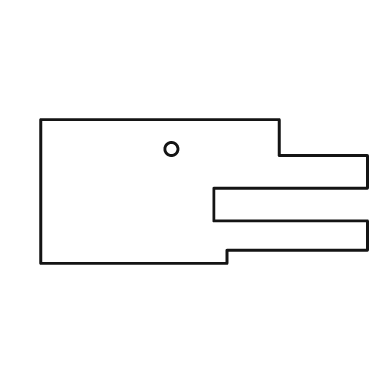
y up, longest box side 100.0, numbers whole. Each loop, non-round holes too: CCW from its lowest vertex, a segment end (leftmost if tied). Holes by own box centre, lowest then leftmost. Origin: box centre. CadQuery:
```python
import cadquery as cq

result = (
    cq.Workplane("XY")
    .moveTo(-50.0, -22.0)
    .lineTo(7.0, -22.0)
    .lineTo(7.0, -18.0)
    .lineTo(50.0, -18.0)
    .lineTo(50.0, -9.0)
    .lineTo(3.0, -9.0)
    .lineTo(3.0, 1.0)
    .lineTo(50.0, 1.0)
    .lineTo(50.0, 11.0)
    .lineTo(23.0, 11.0)
    .lineTo(23.0, 22.0)
    .lineTo(-50.0, 22.0)
    .close()
    .moveTo(-10.0, 13.0)
    .circle(2.0)
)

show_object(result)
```